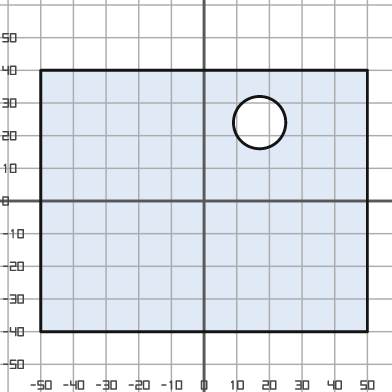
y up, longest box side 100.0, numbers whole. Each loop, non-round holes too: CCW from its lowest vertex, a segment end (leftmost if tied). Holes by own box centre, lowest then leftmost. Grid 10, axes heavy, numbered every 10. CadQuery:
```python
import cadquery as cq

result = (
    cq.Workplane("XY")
    .moveTo(-50.0, -40.0)
    .lineTo(50.0, -40.0)
    .lineTo(50.0, 40.0)
    .lineTo(-50.0, 40.0)
    .close()
    .moveTo(17.0, 24.0)
    .circle(8.0)
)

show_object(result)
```